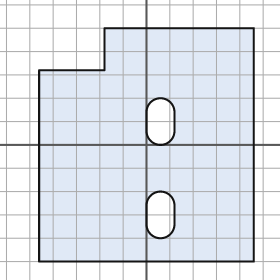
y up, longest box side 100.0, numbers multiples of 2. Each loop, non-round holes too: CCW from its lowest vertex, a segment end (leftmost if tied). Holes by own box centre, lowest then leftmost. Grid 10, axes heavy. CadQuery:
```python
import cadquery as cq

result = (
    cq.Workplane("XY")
    .moveTo(-46.0, -50.0)
    .lineTo(46.0, -50.0)
    .lineTo(46.0, 50.0)
    .lineTo(-18.0, 50.0)
    .lineTo(-18.0, 32.0)
    .lineTo(-46.0, 32.0)
    .close()
    .moveTo(0.0, -34.0)
    .threePointArc((6.0, -40.0), (12.0, -34.0))
    .lineTo(12.0, -26.0)
    .threePointArc((6.0, -20.0), (0.0, -26.0))
    .close()
    .moveTo(0.0, 6.0)
    .threePointArc((6.0, 0.0), (12.0, 6.0))
    .lineTo(12.0, 14.0)
    .threePointArc((6.0, 20.0), (0.0, 14.0))
    .close()
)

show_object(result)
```